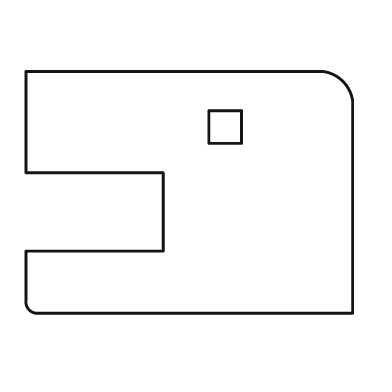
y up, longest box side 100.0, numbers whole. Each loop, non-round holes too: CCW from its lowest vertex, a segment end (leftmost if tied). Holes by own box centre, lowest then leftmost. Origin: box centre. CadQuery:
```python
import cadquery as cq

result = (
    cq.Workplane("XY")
    .moveTo(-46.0, -37.0)
    .lineTo(50.0, -37.0)
    .lineTo(50.0, 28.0)
    .threePointArc((47.0, 34.0), (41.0, 37.0))
    .lineTo(-50.0, 37.0)
    .lineTo(-50.0, 6.0)
    .lineTo(-8.0, 6.0)
    .lineTo(-8.0, -18.0)
    .lineTo(-50.0, -18.0)
    .lineTo(-50.0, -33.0)
    .threePointArc((-49.0, -36.0), (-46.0, -37.0))
    .close()
    .moveTo(6.0, 15.0)
    .lineTo(16.0, 15.0)
    .lineTo(16.0, 25.0)
    .lineTo(6.0, 25.0)
    .close()
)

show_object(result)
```